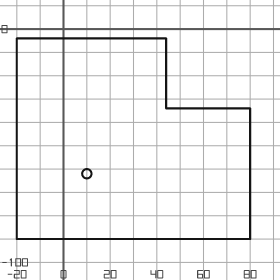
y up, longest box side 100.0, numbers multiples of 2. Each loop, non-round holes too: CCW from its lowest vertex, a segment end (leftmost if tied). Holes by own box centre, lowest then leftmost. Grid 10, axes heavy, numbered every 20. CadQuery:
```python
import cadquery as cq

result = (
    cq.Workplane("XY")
    .moveTo(-20.0, -90.0)
    .lineTo(80.0, -90.0)
    .lineTo(80.0, -34.0)
    .lineTo(44.0, -34.0)
    .lineTo(44.0, -4.0)
    .lineTo(-20.0, -4.0)
    .close()
    .moveTo(10.0, -62.0)
    .circle(2.0)
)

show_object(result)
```